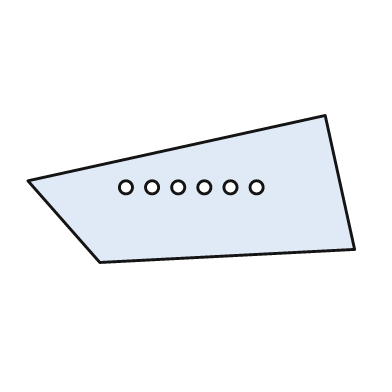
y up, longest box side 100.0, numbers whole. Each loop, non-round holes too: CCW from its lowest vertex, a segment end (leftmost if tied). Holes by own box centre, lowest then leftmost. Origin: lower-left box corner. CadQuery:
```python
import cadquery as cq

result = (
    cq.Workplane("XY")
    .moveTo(22.0, 0.0)
    .lineTo(100.0, 4.0)
    .lineTo(91.0, 45.0)
    .lineTo(0.0, 25.0)
    .close()
    .moveTo(30.0, 23.0)
    .circle(2.0)
    .moveTo(38.0, 23.0)
    .circle(2.0)
    .moveTo(46.0, 23.0)
    .circle(2.0)
    .moveTo(54.0, 23.0)
    .circle(2.0)
    .moveTo(62.0, 23.0)
    .circle(2.0)
    .moveTo(70.0, 23.0)
    .circle(2.0)
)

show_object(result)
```